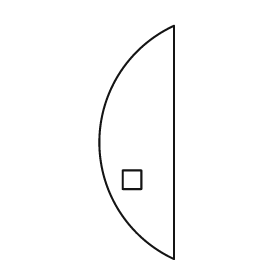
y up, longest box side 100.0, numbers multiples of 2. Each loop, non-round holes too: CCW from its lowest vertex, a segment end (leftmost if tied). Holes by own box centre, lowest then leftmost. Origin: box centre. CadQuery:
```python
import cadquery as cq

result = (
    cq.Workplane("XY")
    .moveTo(16.0, -50.0)
    .lineTo(16.0, 50.0)
    .threePointArc((-16.0, 0.0), (16.0, -50.0))
    .close()
    .moveTo(-6.0, -20.0)
    .lineTo(2.0, -20.0)
    .lineTo(2.0, -12.0)
    .lineTo(-6.0, -12.0)
    .close()
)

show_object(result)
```